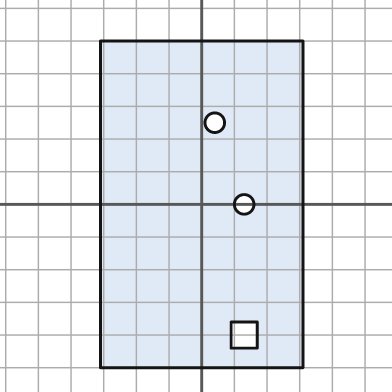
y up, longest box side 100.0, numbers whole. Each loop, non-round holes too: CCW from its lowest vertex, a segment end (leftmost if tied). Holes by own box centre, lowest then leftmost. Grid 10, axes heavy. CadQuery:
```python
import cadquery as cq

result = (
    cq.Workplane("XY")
    .moveTo(-31.0, -50.0)
    .lineTo(31.0, -50.0)
    .lineTo(31.0, 50.0)
    .lineTo(-31.0, 50.0)
    .close()
    .moveTo(9.0, -44.0)
    .lineTo(17.0, -44.0)
    .lineTo(17.0, -36.0)
    .lineTo(9.0, -36.0)
    .close()
    .moveTo(13.0, 0.0)
    .circle(3.0)
    .moveTo(4.0, 25.0)
    .circle(3.0)
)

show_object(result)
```